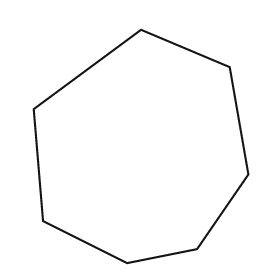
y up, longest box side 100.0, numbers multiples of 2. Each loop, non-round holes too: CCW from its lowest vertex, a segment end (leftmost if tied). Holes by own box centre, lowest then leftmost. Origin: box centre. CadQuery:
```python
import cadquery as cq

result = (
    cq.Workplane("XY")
    .moveTo(-6.0, -50.0)
    .lineTo(24.0, -44.0)
    .lineTo(46.0, -12.0)
    .lineTo(38.0, 34.0)
    .lineTo(0.0, 50.0)
    .lineTo(-46.0, 16.0)
    .lineTo(-42.0, -32.0)
    .close()
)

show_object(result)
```